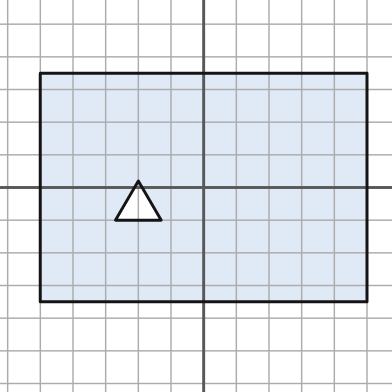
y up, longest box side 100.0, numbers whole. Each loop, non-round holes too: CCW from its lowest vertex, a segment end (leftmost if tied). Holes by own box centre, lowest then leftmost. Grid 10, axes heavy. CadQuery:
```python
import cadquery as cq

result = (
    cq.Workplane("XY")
    .moveTo(-50.0, -35.0)
    .lineTo(50.0, -35.0)
    .lineTo(50.0, 35.0)
    .lineTo(-50.0, 35.0)
    .close()
    .moveTo(-27.0, -10.0)
    .lineTo(-13.0, -10.0)
    .lineTo(-20.0, 2.0)
    .close()
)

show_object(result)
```